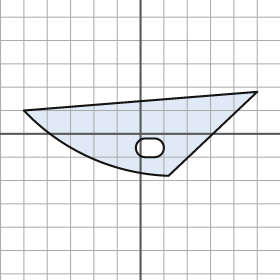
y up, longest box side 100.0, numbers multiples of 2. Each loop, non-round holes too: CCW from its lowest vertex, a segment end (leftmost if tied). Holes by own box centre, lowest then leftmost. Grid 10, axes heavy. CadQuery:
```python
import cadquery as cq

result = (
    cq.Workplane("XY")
    .moveTo(12.0, -18.0)
    .lineTo(50.0, 18.0)
    .lineTo(-50.0, 10.0)
    .threePointArc((-22.0, -10.0), (12.0, -18.0))
    .close()
    .moveTo(2.0, -10.0)
    .lineTo(6.0, -10.0)
    .threePointArc((10.0, -6.0), (6.0, -2.0))
    .lineTo(2.0, -2.0)
    .threePointArc((-2.0, -6.0), (2.0, -10.0))
    .close()
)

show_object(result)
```